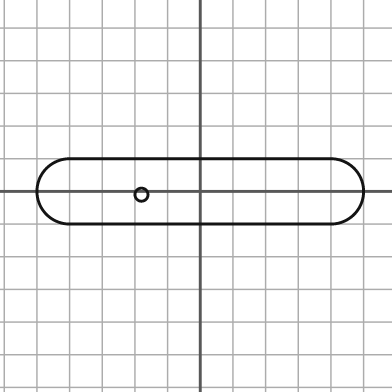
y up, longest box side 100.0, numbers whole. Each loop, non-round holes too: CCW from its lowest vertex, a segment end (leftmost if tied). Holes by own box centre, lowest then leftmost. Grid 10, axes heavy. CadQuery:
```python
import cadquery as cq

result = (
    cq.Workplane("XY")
    .moveTo(-40.0, -10.0)
    .lineTo(40.0, -10.0)
    .threePointArc((50.0, 0.0), (40.0, 10.0))
    .lineTo(-40.0, 10.0)
    .threePointArc((-50.0, 0.0), (-40.0, -10.0))
    .close()
    .moveTo(-18.0, -1.0)
    .circle(2.0)
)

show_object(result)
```